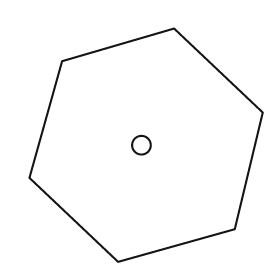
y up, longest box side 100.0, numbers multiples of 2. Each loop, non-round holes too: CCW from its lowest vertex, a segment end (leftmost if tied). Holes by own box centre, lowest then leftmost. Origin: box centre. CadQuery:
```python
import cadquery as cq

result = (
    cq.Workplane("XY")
    .moveTo(-12.0, -50.0)
    .lineTo(38.0, -36.0)
    .lineTo(50.0, 14.0)
    .lineTo(12.0, 50.0)
    .lineTo(-36.0, 36.0)
    .lineTo(-50.0, -14.0)
    .close()
    .moveTo(-2.0, 0.0)
    .circle(4.0)
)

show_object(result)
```